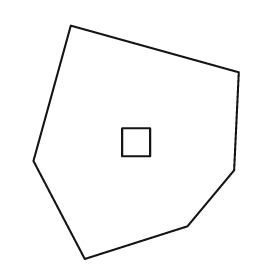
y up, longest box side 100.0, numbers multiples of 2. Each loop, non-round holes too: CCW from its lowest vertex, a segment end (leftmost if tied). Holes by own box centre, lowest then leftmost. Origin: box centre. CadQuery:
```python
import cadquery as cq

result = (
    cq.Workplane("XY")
    .moveTo(-22.0, -50.0)
    .lineTo(22.0, -36.0)
    .lineTo(42.0, -12.0)
    .lineTo(44.0, 30.0)
    .lineTo(-28.0, 50.0)
    .lineTo(-44.0, -8.0)
    .close()
    .moveTo(-6.0, -6.0)
    .lineTo(6.0, -6.0)
    .lineTo(6.0, 6.0)
    .lineTo(-6.0, 6.0)
    .close()
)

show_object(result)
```